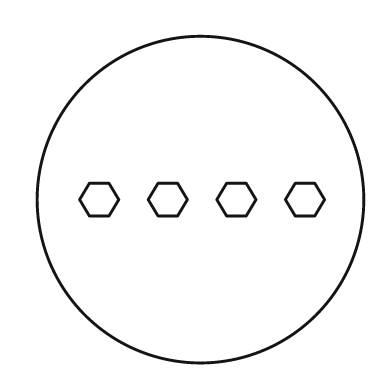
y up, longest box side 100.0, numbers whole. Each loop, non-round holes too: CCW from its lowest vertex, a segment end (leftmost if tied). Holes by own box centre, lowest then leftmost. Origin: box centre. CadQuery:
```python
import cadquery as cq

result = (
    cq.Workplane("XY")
    .moveTo(0.0, 0.0)
    .circle(50.0)
    .moveTo(-34.0, -5.0)
    .lineTo(-28.0, -5.0)
    .lineTo(-25.0, 0.0)
    .lineTo(-28.0, 5.0)
    .lineTo(-34.0, 5.0)
    .lineTo(-37.0, 0.0)
    .close()
    .moveTo(-13.0, -5.0)
    .lineTo(-7.0, -5.0)
    .lineTo(-4.0, 0.0)
    .lineTo(-7.0, 5.0)
    .lineTo(-13.0, 5.0)
    .lineTo(-16.0, 0.0)
    .close()
    .moveTo(8.0, -5.0)
    .lineTo(14.0, -5.0)
    .lineTo(17.0, 0.0)
    .lineTo(14.0, 5.0)
    .lineTo(8.0, 5.0)
    .lineTo(5.0, 0.0)
    .close()
    .moveTo(29.0, -5.0)
    .lineTo(35.0, -5.0)
    .lineTo(38.0, 0.0)
    .lineTo(35.0, 5.0)
    .lineTo(29.0, 5.0)
    .lineTo(26.0, 0.0)
    .close()
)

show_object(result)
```